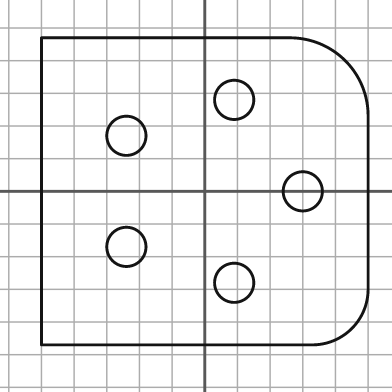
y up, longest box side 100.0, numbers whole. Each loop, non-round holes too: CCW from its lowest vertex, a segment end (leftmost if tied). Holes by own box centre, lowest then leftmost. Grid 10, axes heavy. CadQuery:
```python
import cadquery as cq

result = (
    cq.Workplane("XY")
    .moveTo(-50.0, -47.0)
    .lineTo(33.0, -47.0)
    .threePointArc((45.0, -42.0), (50.0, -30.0))
    .lineTo(50.0, 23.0)
    .threePointArc((43.0, 40.0), (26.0, 47.0))
    .lineTo(-50.0, 47.0)
    .close()
    .moveTo(9.0, -28.0)
    .circle(6.0)
    .moveTo(-24.0, -17.0)
    .circle(6.0)
    .moveTo(30.0, 0.0)
    .circle(6.0)
    .moveTo(-24.0, 17.0)
    .circle(6.0)
    .moveTo(9.0, 28.0)
    .circle(6.0)
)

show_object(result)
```